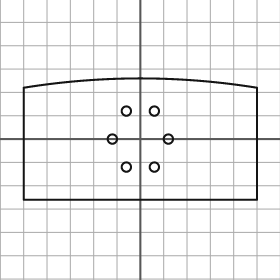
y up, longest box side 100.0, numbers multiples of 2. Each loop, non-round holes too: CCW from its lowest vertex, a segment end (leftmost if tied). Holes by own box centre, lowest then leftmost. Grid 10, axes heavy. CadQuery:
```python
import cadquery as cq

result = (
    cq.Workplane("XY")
    .moveTo(-50.0, -26.0)
    .lineTo(50.0, -26.0)
    .lineTo(50.0, 22.0)
    .threePointArc((0.0, 26.0), (-50.0, 22.0))
    .close()
    .moveTo(-6.0, -12.0)
    .circle(2.0)
    .moveTo(6.0, -12.0)
    .circle(2.0)
    .moveTo(-12.0, 0.0)
    .circle(2.0)
    .moveTo(12.0, 0.0)
    .circle(2.0)
    .moveTo(-6.0, 12.0)
    .circle(2.0)
    .moveTo(6.0, 12.0)
    .circle(2.0)
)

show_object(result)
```